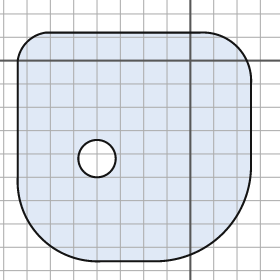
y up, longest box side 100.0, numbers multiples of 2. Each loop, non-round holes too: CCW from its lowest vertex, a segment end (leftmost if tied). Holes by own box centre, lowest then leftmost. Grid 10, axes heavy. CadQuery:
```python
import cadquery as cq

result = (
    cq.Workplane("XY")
    .moveTo(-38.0, -86.0)
    .lineTo(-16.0, -86.0)
    .threePointArc((14.0, -74.0), (26.0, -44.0))
    .lineTo(26.0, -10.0)
    .threePointArc((20.0, 6.0), (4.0, 12.0))
    .lineTo(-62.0, 12.0)
    .threePointArc((-70.0, 8.0), (-74.0, 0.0))
    .lineTo(-74.0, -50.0)
    .threePointArc((-64.0, -76.0), (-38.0, -86.0))
    .close()
    .moveTo(-40.0, -42.0)
    .circle(8.0)
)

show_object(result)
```